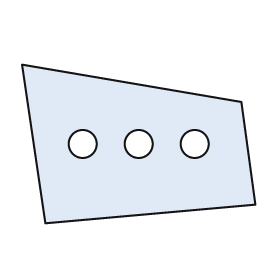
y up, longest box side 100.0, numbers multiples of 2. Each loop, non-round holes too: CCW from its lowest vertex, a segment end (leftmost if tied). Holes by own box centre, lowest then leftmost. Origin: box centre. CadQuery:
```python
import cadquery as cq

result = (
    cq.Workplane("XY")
    .moveTo(-40.0, -34.0)
    .lineTo(50.0, -26.0)
    .lineTo(44.0, 18.0)
    .lineTo(-50.0, 34.0)
    .close()
    .moveTo(-24.0, 0.0)
    .circle(6.0)
    .moveTo(0.0, 0.0)
    .circle(6.0)
    .moveTo(24.0, 0.0)
    .circle(6.0)
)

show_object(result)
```